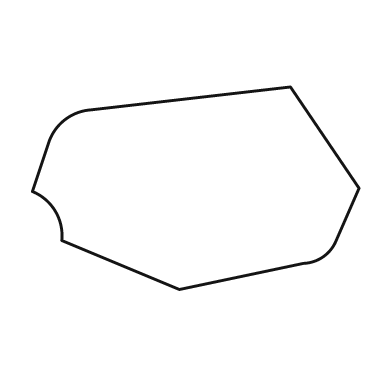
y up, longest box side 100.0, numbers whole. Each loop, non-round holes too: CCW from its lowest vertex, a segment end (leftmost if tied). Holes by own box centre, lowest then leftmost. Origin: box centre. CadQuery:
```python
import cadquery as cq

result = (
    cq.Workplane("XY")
    .moveTo(-5.0, -31.0)
    .lineTo(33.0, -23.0)
    .threePointArc((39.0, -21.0), (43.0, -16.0))
    .lineTo(50.0, 0.0)
    .lineTo(29.0, 31.0)
    .lineTo(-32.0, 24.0)
    .threePointArc((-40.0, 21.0), (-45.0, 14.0))
    .lineTo(-50.0, -1.0)
    .threePointArc((-43.0, -7.0), (-41.0, -16.0))
    .close()
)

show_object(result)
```